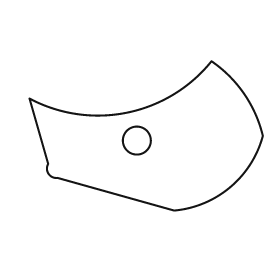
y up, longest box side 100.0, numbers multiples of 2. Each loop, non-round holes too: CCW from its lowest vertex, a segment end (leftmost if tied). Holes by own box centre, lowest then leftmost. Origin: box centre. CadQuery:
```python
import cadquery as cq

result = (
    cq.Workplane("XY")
    .moveTo(12.0, -32.0)
    .threePointArc((36.0, -22.0), (50.0, 0.0))
    .threePointArc((42.0, 18.0), (28.0, 32.0))
    .threePointArc((-8.0, 10.0), (-50.0, 16.0))
    .lineTo(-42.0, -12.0)
    .threePointArc((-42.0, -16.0), (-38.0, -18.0))
    .close()
    .moveTo(-4.0, -2.0)
    .circle(6.0)
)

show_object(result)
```